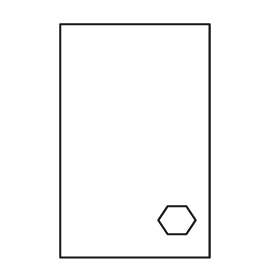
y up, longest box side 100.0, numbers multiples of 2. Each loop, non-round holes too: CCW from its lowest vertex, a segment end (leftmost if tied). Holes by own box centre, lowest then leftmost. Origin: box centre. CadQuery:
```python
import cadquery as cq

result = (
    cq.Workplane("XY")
    .moveTo(-32.0, -50.0)
    .lineTo(32.0, -50.0)
    .lineTo(32.0, 50.0)
    .lineTo(-32.0, 50.0)
    .close()
    .moveTo(14.0, -40.0)
    .lineTo(22.0, -40.0)
    .lineTo(26.0, -34.0)
    .lineTo(22.0, -28.0)
    .lineTo(14.0, -28.0)
    .lineTo(10.0, -34.0)
    .close()
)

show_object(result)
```